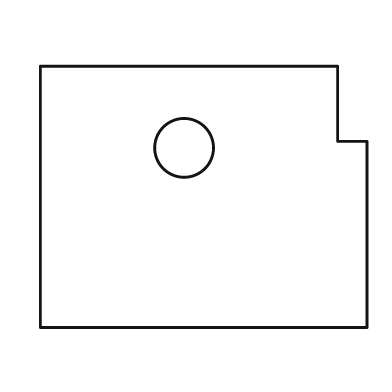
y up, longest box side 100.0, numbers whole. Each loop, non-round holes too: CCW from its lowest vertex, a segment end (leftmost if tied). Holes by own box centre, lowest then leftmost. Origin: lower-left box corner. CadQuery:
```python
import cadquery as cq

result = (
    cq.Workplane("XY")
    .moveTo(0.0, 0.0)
    .lineTo(100.0, 0.0)
    .lineTo(100.0, 57.0)
    .lineTo(91.0, 57.0)
    .lineTo(91.0, 80.0)
    .lineTo(0.0, 80.0)
    .close()
    .moveTo(44.0, 55.0)
    .circle(9.0)
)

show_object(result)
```